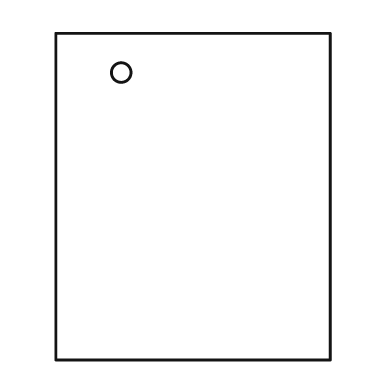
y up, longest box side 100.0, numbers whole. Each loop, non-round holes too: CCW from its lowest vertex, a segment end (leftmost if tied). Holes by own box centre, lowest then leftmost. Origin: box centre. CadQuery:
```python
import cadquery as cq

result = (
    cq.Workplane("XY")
    .moveTo(-42.0, -50.0)
    .lineTo(42.0, -50.0)
    .lineTo(42.0, 50.0)
    .lineTo(-42.0, 50.0)
    .close()
    .moveTo(-22.0, 38.0)
    .circle(3.0)
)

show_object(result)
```